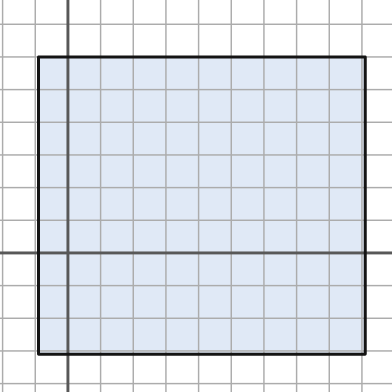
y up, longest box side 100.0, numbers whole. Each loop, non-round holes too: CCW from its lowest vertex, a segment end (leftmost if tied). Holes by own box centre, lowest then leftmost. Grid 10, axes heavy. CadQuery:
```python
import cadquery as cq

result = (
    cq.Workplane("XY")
    .moveTo(-9.0, -31.0)
    .lineTo(91.0, -31.0)
    .lineTo(91.0, 60.0)
    .lineTo(-9.0, 60.0)
    .close()
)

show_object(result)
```